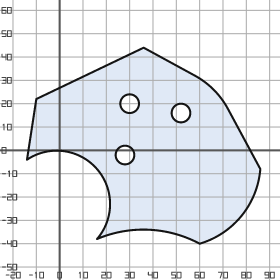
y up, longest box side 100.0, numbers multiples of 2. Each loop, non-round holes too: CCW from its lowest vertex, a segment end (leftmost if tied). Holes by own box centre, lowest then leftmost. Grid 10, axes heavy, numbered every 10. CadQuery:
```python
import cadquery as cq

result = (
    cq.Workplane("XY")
    .moveTo(60.0, -40.0)
    .threePointArc((78.0, -28.0), (86.0, -8.0))
    .lineTo(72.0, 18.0)
    .threePointArc((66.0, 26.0), (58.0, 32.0))
    .lineTo(36.0, 44.0)
    .lineTo(-10.0, 22.0)
    .lineTo(-14.0, -4.0)
    .threePointArc((16.0, -8.0), (16.0, -38.0))
    .threePointArc((38.0, -34.0), (60.0, -40.0))
    .close()
    .moveTo(28.0, -2.0)
    .circle(4.0)
    .moveTo(52.0, 16.0)
    .circle(4.0)
    .moveTo(30.0, 20.0)
    .circle(4.0)
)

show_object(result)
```